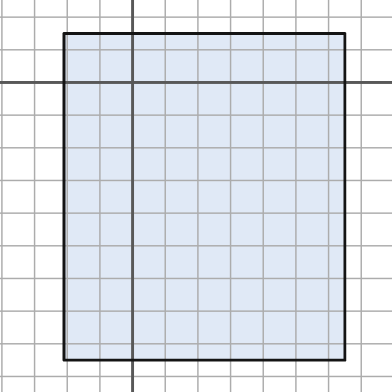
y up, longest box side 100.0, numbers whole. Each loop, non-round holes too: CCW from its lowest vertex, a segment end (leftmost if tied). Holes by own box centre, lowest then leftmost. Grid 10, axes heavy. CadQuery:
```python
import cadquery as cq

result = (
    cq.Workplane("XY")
    .moveTo(-21.0, -85.0)
    .lineTo(65.0, -85.0)
    .lineTo(65.0, 15.0)
    .lineTo(-21.0, 15.0)
    .close()
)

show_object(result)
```